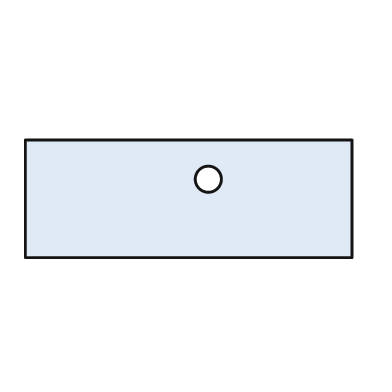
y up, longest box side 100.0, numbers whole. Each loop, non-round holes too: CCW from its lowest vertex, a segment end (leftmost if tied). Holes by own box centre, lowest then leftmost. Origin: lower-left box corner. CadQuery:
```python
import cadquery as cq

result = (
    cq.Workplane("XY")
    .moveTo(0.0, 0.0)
    .lineTo(100.0, 0.0)
    .lineTo(100.0, 36.0)
    .lineTo(0.0, 36.0)
    .close()
    .moveTo(56.0, 24.0)
    .circle(4.0)
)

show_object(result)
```